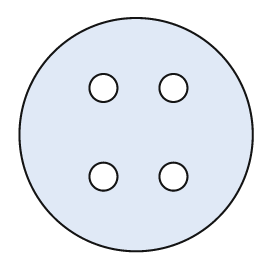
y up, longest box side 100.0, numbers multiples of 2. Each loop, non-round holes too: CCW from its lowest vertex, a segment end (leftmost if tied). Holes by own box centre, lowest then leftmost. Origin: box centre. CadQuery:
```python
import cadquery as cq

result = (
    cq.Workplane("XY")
    .moveTo(0.0, 0.0)
    .circle(50.0)
    .moveTo(-14.0, -18.0)
    .circle(6.0)
    .moveTo(16.0, -18.0)
    .circle(6.0)
    .moveTo(-14.0, 20.0)
    .circle(6.0)
    .moveTo(16.0, 20.0)
    .circle(6.0)
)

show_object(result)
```